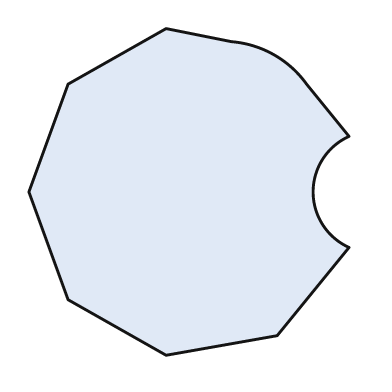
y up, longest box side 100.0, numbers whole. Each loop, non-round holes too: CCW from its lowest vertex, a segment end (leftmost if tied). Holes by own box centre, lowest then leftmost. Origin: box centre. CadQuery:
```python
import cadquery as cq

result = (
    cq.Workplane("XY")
    .moveTo(-7.0, -50.0)
    .lineTo(27.0, -44.0)
    .lineTo(49.0, -17.0)
    .threePointArc((38.0, 0.0), (49.0, 17.0))
    .lineTo(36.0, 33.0)
    .threePointArc((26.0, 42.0), (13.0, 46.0))
    .lineTo(-7.0, 50.0)
    .lineTo(-37.0, 33.0)
    .lineTo(-49.0, 0.0)
    .lineTo(-37.0, -33.0)
    .close()
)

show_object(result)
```